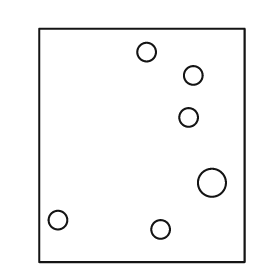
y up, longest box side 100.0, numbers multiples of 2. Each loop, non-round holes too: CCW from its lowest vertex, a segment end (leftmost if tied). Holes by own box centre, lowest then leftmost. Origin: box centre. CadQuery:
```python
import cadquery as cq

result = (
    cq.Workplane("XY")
    .moveTo(-44.0, -50.0)
    .lineTo(44.0, -50.0)
    .lineTo(44.0, 50.0)
    .lineTo(-44.0, 50.0)
    .close()
    .moveTo(8.0, -36.0)
    .circle(4.0)
    .moveTo(-36.0, -32.0)
    .circle(4.0)
    .moveTo(30.0, -16.0)
    .circle(6.0)
    .moveTo(20.0, 12.0)
    .circle(4.0)
    .moveTo(22.0, 30.0)
    .circle(4.0)
    .moveTo(2.0, 40.0)
    .circle(4.0)
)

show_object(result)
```